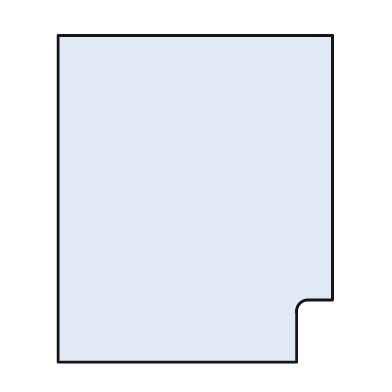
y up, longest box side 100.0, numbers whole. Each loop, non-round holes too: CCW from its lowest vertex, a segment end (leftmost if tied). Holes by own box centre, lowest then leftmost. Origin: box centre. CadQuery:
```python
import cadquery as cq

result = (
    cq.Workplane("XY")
    .moveTo(-42.0, -50.0)
    .lineTo(31.0, -50.0)
    .lineTo(31.0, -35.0)
    .threePointArc((32.0, -32.0), (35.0, -31.0))
    .lineTo(42.0, -31.0)
    .lineTo(42.0, 50.0)
    .lineTo(-42.0, 50.0)
    .close()
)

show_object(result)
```